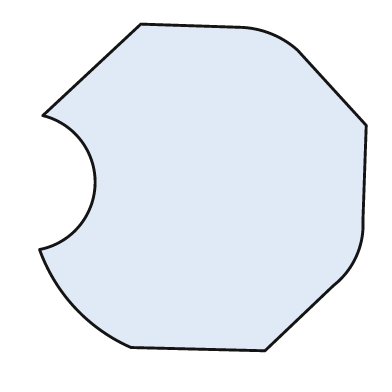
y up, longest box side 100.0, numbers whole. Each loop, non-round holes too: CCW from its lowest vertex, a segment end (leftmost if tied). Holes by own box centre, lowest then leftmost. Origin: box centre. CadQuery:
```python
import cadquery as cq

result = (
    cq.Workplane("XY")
    .moveTo(19.0, -50.0)
    .lineTo(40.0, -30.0)
    .threePointArc((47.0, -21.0), (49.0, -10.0))
    .lineTo(50.0, 19.0)
    .lineTo(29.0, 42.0)
    .threePointArc((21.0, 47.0), (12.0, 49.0))
    .lineTo(-19.0, 50.0)
    .lineTo(-49.0, 22.0)
    .threePointArc((-33.0, 1.0), (-50.0, -19.0))
    .threePointArc((-39.0, -37.0), (-22.0, -49.0))
    .close()
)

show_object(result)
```